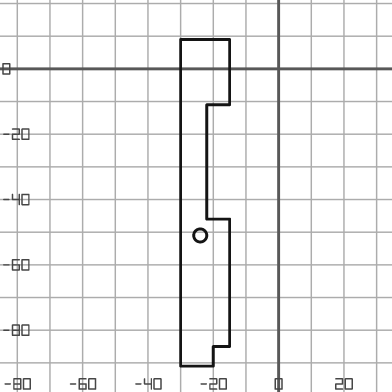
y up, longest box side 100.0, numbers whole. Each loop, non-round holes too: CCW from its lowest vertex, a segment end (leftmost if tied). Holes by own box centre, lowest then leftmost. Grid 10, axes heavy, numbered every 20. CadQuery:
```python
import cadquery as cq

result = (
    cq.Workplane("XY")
    .moveTo(-30.0, -91.0)
    .lineTo(-20.0, -91.0)
    .lineTo(-20.0, -85.0)
    .lineTo(-15.0, -85.0)
    .lineTo(-15.0, -46.0)
    .lineTo(-22.0, -46.0)
    .lineTo(-22.0, -11.0)
    .lineTo(-15.0, -11.0)
    .lineTo(-15.0, 9.0)
    .lineTo(-30.0, 9.0)
    .close()
    .moveTo(-24.0, -51.0)
    .circle(2.0)
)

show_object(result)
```